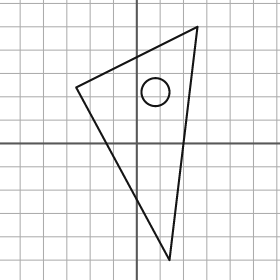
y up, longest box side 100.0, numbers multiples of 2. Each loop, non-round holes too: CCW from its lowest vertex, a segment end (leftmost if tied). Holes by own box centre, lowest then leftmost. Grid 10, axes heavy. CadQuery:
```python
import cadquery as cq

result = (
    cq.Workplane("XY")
    .moveTo(14.0, -50.0)
    .lineTo(26.0, 50.0)
    .lineTo(-26.0, 24.0)
    .close()
    .moveTo(8.0, 22.0)
    .circle(6.0)
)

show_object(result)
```